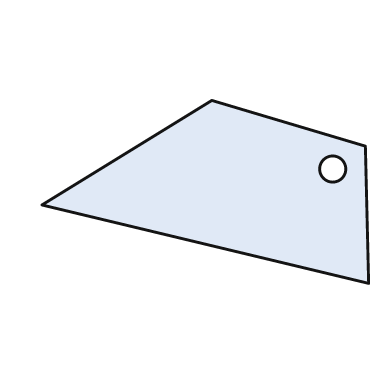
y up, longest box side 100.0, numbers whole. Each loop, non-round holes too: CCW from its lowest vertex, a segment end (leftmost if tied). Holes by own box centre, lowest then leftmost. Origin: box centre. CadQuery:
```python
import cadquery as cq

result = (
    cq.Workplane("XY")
    .moveTo(50.0, -28.0)
    .lineTo(49.0, 14.0)
    .lineTo(2.0, 28.0)
    .lineTo(-50.0, -4.0)
    .close()
    .moveTo(39.0, 7.0)
    .circle(4.0)
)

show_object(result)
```